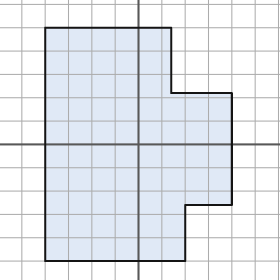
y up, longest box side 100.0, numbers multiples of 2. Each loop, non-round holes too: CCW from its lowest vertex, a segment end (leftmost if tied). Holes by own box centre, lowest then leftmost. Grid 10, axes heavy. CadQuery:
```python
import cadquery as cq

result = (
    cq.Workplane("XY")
    .moveTo(-40.0, -50.0)
    .lineTo(20.0, -50.0)
    .lineTo(20.0, -26.0)
    .lineTo(40.0, -26.0)
    .lineTo(40.0, 22.0)
    .lineTo(14.0, 22.0)
    .lineTo(14.0, 50.0)
    .lineTo(-40.0, 50.0)
    .close()
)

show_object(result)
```